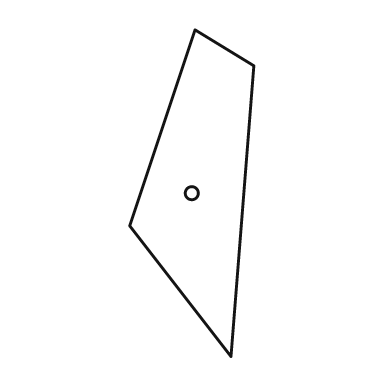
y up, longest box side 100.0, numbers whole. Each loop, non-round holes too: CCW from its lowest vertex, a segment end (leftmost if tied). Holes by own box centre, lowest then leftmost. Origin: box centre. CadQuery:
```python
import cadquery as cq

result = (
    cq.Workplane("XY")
    .moveTo(12.0, -50.0)
    .lineTo(19.0, 39.0)
    .lineTo(1.0, 50.0)
    .lineTo(-19.0, -10.0)
    .close()
    .moveTo(0.0, 0.0)
    .circle(2.0)
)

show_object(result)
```